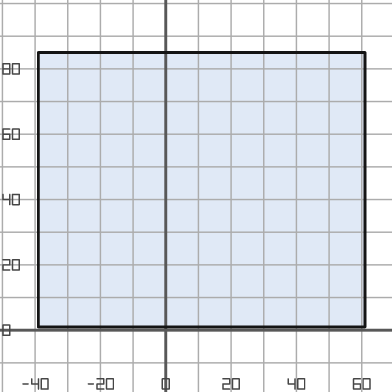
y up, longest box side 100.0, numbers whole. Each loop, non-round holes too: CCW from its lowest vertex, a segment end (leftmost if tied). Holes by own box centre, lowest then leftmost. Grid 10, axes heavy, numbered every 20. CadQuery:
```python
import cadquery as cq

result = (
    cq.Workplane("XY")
    .moveTo(-39.0, 1.0)
    .lineTo(61.0, 1.0)
    .lineTo(61.0, 85.0)
    .lineTo(-39.0, 85.0)
    .close()
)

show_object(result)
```